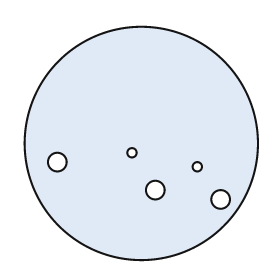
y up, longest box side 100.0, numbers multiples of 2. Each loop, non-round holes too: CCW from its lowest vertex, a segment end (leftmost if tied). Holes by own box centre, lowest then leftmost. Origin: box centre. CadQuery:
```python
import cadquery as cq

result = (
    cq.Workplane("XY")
    .moveTo(0.0, 0.0)
    .circle(50.0)
    .moveTo(34.0, -24.0)
    .circle(4.0)
    .moveTo(6.0, -20.0)
    .circle(4.0)
    .moveTo(24.0, -10.0)
    .circle(2.0)
    .moveTo(-36.0, -8.0)
    .circle(4.0)
    .moveTo(-4.0, -4.0)
    .circle(2.0)
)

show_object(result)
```